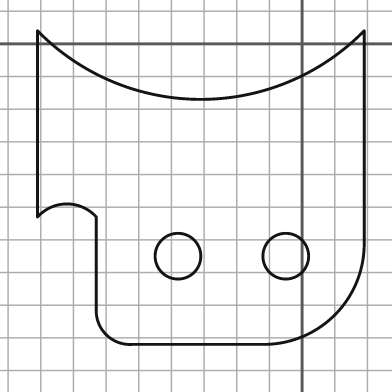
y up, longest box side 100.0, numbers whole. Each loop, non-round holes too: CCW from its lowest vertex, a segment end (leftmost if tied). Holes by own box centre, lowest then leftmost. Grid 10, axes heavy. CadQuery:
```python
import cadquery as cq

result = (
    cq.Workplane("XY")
    .moveTo(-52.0, -92.0)
    .lineTo(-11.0, -92.0)
    .threePointArc((10.0, -83.0), (19.0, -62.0))
    .lineTo(19.0, 4.0)
    .threePointArc((-31.0, -17.0), (-81.0, 4.0))
    .lineTo(-81.0, -53.0)
    .threePointArc((-72.0, -49.0), (-63.0, -53.0))
    .lineTo(-63.0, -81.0)
    .threePointArc((-60.0, -89.0), (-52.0, -92.0))
    .close()
    .moveTo(-38.0, -65.0)
    .circle(7.0)
    .moveTo(-5.0, -65.0)
    .circle(7.0)
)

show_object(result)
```